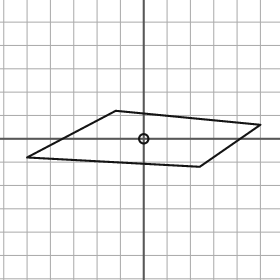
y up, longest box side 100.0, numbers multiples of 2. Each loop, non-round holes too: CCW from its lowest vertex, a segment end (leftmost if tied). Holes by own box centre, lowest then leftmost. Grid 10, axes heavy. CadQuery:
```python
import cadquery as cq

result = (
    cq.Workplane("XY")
    .moveTo(24.0, -12.0)
    .lineTo(50.0, 6.0)
    .lineTo(-12.0, 12.0)
    .lineTo(-50.0, -8.0)
    .close()
    .moveTo(0.0, 0.0)
    .circle(2.0)
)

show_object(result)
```